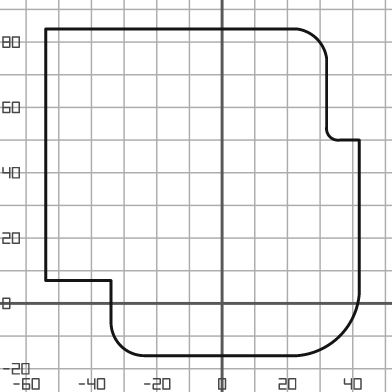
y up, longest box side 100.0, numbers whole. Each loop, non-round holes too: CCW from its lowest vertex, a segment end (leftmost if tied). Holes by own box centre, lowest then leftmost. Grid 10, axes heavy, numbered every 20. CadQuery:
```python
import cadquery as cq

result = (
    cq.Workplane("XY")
    .moveTo(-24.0, -16.0)
    .lineTo(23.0, -16.0)
    .threePointArc((36.0, -10.0), (42.0, 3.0))
    .lineTo(42.0, 50.0)
    .lineTo(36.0, 50.0)
    .threePointArc((33.0, 51.0), (32.0, 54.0))
    .lineTo(32.0, 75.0)
    .threePointArc((29.0, 81.0), (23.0, 84.0))
    .lineTo(-54.0, 84.0)
    .lineTo(-54.0, 7.0)
    .lineTo(-34.0, 7.0)
    .lineTo(-34.0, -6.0)
    .threePointArc((-31.0, -13.0), (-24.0, -16.0))
    .close()
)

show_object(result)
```